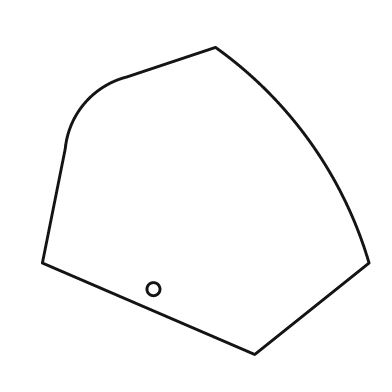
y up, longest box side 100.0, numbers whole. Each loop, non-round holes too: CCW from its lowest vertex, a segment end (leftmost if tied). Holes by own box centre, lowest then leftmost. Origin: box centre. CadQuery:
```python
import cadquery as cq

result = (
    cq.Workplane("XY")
    .moveTo(15.0, -47.0)
    .lineTo(50.0, -19.0)
    .threePointArc((32.0, 18.0), (3.0, 47.0))
    .lineTo(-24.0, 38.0)
    .threePointArc((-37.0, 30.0), (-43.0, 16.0))
    .lineTo(-50.0, -19.0)
    .close()
    .moveTo(-16.0, -27.0)
    .circle(2.0)
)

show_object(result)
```